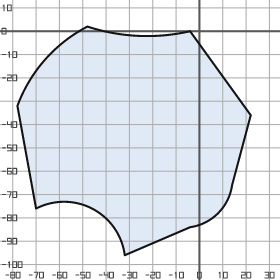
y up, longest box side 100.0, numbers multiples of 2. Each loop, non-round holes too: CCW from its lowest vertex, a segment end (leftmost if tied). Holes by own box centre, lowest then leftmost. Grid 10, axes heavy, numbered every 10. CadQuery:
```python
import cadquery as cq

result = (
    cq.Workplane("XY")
    .moveTo(-32.0, -96.0)
    .lineTo(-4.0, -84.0)
    .threePointArc((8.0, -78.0), (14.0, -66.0))
    .lineTo(22.0, -36.0)
    .lineTo(-4.0, 0.0)
    .threePointArc((-26.0, -2.0), (-48.0, 2.0))
    .threePointArc((-66.0, -12.0), (-78.0, -32.0))
    .lineTo(-70.0, -76.0)
    .threePointArc((-46.0, -76.0), (-32.0, -96.0))
    .close()
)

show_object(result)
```